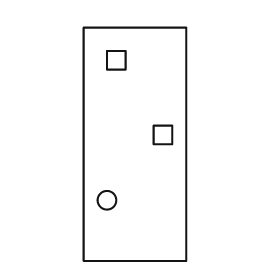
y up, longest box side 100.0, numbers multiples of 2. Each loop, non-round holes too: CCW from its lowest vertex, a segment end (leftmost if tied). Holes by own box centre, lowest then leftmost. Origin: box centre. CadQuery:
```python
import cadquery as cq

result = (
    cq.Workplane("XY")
    .moveTo(-22.0, -50.0)
    .lineTo(22.0, -50.0)
    .lineTo(22.0, 50.0)
    .lineTo(-22.0, 50.0)
    .close()
    .moveTo(-12.0, -24.0)
    .circle(4.0)
    .moveTo(8.0, 0.0)
    .lineTo(16.0, 0.0)
    .lineTo(16.0, 8.0)
    .lineTo(8.0, 8.0)
    .close()
    .moveTo(-12.0, 32.0)
    .lineTo(-4.0, 32.0)
    .lineTo(-4.0, 40.0)
    .lineTo(-12.0, 40.0)
    .close()
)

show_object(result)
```